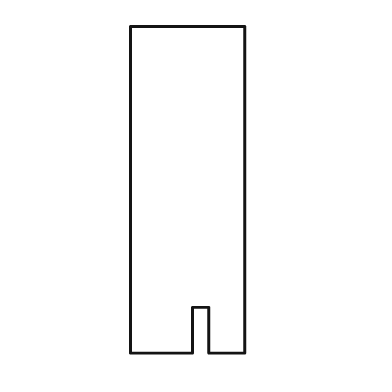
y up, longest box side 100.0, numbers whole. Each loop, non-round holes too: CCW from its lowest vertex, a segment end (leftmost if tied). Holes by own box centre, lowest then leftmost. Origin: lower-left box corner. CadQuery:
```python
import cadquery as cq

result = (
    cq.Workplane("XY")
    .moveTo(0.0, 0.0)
    .lineTo(19.0, 0.0)
    .lineTo(19.0, 14.0)
    .lineTo(24.0, 14.0)
    .lineTo(24.0, 0.0)
    .lineTo(35.0, 0.0)
    .lineTo(35.0, 100.0)
    .lineTo(0.0, 100.0)
    .close()
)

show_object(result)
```